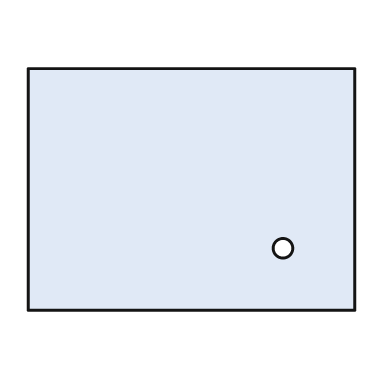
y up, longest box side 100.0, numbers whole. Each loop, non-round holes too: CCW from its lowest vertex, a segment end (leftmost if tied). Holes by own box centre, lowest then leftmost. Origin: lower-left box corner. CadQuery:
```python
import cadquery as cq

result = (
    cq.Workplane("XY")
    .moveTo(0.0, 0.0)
    .lineTo(100.0, 0.0)
    .lineTo(100.0, 74.0)
    .lineTo(0.0, 74.0)
    .close()
    .moveTo(78.0, 19.0)
    .circle(3.0)
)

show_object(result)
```